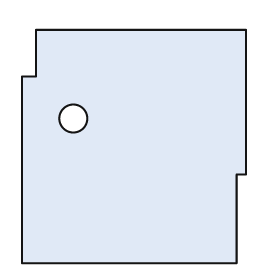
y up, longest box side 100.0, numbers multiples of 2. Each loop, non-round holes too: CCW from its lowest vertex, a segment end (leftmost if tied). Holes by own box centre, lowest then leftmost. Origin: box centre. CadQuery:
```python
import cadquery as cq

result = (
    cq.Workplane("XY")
    .moveTo(-48.0, -50.0)
    .lineTo(44.0, -50.0)
    .lineTo(44.0, -12.0)
    .lineTo(48.0, -12.0)
    .lineTo(48.0, 50.0)
    .lineTo(-42.0, 50.0)
    .lineTo(-42.0, 30.0)
    .lineTo(-48.0, 30.0)
    .close()
    .moveTo(-26.0, 12.0)
    .circle(6.0)
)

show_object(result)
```